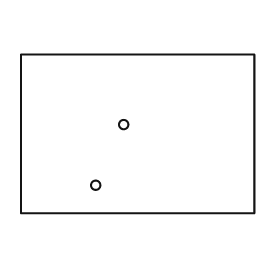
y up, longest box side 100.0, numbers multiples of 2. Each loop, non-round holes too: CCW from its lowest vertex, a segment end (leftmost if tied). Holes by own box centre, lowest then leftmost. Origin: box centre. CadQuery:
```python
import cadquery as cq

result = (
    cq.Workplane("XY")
    .moveTo(-50.0, -34.0)
    .lineTo(50.0, -34.0)
    .lineTo(50.0, 34.0)
    .lineTo(-50.0, 34.0)
    .close()
    .moveTo(-18.0, -22.0)
    .circle(2.0)
    .moveTo(-6.0, 4.0)
    .circle(2.0)
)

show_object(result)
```